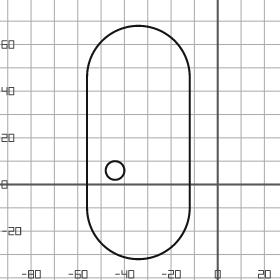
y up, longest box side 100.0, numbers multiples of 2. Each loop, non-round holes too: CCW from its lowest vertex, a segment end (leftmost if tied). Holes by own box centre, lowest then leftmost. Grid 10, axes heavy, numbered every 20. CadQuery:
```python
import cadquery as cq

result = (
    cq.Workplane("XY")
    .moveTo(-56.0, -10.0)
    .threePointArc((-34.0, -32.0), (-12.0, -10.0))
    .lineTo(-12.0, 46.0)
    .threePointArc((-34.0, 68.0), (-56.0, 46.0))
    .close()
    .moveTo(-44.0, 6.0)
    .circle(4.0)
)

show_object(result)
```